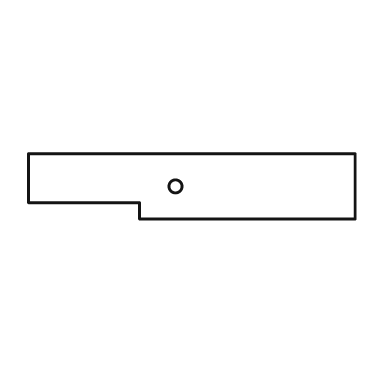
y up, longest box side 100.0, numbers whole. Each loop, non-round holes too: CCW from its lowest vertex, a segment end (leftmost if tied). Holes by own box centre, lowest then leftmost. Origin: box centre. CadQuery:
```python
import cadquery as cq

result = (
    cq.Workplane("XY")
    .moveTo(-16.0, -10.0)
    .lineTo(50.0, -10.0)
    .lineTo(50.0, 10.0)
    .lineTo(-50.0, 10.0)
    .lineTo(-50.0, -5.0)
    .lineTo(-16.0, -5.0)
    .close()
    .moveTo(-5.0, 0.0)
    .circle(2.0)
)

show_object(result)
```